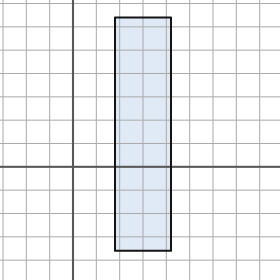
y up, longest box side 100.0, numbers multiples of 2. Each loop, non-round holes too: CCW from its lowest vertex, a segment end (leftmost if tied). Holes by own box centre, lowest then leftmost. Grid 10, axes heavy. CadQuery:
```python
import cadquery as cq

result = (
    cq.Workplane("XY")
    .moveTo(18.0, -36.0)
    .lineTo(42.0, -36.0)
    .lineTo(42.0, 64.0)
    .lineTo(18.0, 64.0)
    .close()
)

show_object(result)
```